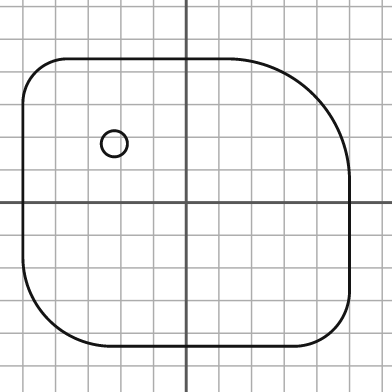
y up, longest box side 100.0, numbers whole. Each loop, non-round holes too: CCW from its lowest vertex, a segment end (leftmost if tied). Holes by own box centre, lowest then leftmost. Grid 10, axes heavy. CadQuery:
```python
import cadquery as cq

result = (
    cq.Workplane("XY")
    .moveTo(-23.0, -44.0)
    .lineTo(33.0, -44.0)
    .threePointArc((45.0, -39.0), (50.0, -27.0))
    .lineTo(50.0, 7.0)
    .threePointArc((39.0, 33.0), (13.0, 44.0))
    .lineTo(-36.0, 44.0)
    .threePointArc((-46.0, 40.0), (-50.0, 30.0))
    .lineTo(-50.0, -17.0)
    .threePointArc((-42.0, -36.0), (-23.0, -44.0))
    .close()
    .moveTo(-22.0, 18.0)
    .circle(4.0)
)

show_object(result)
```